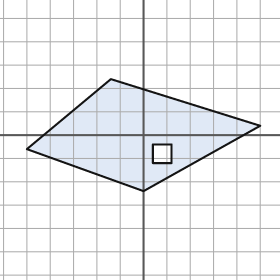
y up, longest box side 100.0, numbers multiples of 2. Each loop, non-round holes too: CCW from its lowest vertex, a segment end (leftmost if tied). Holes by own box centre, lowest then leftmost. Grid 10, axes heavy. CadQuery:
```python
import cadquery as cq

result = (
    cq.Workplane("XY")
    .moveTo(0.0, -24.0)
    .lineTo(50.0, 4.0)
    .lineTo(-14.0, 24.0)
    .lineTo(-50.0, -6.0)
    .close()
    .moveTo(4.0, -12.0)
    .lineTo(12.0, -12.0)
    .lineTo(12.0, -4.0)
    .lineTo(4.0, -4.0)
    .close()
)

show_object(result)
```